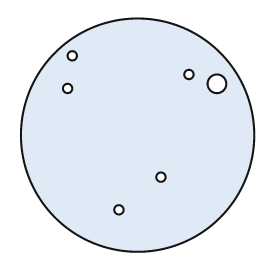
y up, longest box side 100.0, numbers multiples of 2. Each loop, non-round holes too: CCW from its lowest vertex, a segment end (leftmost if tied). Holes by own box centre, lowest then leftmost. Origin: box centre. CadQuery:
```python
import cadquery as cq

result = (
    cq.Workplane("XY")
    .moveTo(0.0, 0.0)
    .circle(50.0)
    .moveTo(-8.0, -32.0)
    .circle(2.0)
    .moveTo(10.0, -18.0)
    .circle(2.0)
    .moveTo(-30.0, 20.0)
    .circle(2.0)
    .moveTo(34.0, 22.0)
    .circle(4.0)
    .moveTo(22.0, 26.0)
    .circle(2.0)
    .moveTo(-28.0, 34.0)
    .circle(2.0)
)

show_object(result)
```